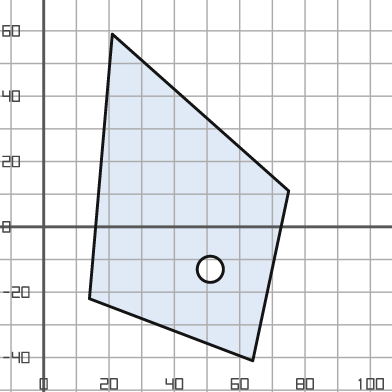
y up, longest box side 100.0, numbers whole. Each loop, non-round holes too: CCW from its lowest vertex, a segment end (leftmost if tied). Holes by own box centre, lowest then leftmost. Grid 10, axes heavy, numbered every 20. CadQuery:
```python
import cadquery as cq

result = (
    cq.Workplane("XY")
    .moveTo(64.0, -41.0)
    .lineTo(75.0, 11.0)
    .lineTo(21.0, 59.0)
    .lineTo(14.0, -22.0)
    .close()
    .moveTo(51.0, -13.0)
    .circle(4.0)
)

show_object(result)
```